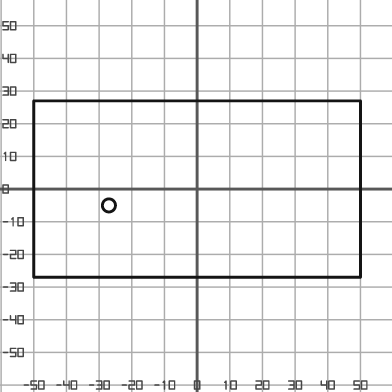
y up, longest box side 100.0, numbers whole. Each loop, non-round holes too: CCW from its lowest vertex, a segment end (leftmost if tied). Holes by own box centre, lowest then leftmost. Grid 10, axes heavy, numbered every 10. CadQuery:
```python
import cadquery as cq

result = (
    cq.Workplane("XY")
    .moveTo(-50.0, -27.0)
    .lineTo(50.0, -27.0)
    .lineTo(50.0, 27.0)
    .lineTo(-50.0, 27.0)
    .close()
    .moveTo(-27.0, -5.0)
    .circle(2.0)
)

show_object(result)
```